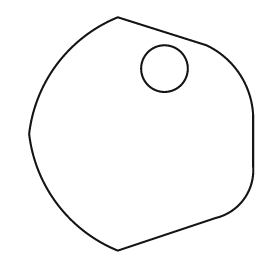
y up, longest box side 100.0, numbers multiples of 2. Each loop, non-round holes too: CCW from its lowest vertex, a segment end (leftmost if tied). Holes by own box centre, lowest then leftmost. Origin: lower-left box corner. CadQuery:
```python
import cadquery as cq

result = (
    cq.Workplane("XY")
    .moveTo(38.0, 0.0)
    .lineTo(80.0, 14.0)
    .threePointArc((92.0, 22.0), (96.0, 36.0))
    .lineTo(96.0, 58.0)
    .threePointArc((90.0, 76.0), (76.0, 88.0))
    .lineTo(38.0, 100.0)
    .threePointArc((12.0, 80.0), (0.0, 50.0))
    .threePointArc((12.0, 20.0), (38.0, 0.0))
    .close()
    .moveTo(58.0, 78.0)
    .circle(10.0)
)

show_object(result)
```